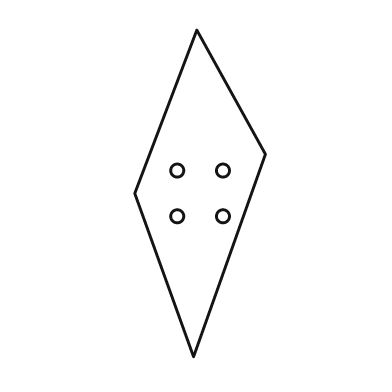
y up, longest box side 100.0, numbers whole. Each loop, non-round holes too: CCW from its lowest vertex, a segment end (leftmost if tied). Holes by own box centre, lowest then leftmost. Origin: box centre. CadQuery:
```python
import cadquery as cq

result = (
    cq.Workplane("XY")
    .moveTo(-2.0, -50.0)
    .lineTo(20.0, 12.0)
    .lineTo(-1.0, 50.0)
    .lineTo(-20.0, 0.0)
    .close()
    .moveTo(-7.0, -7.0)
    .circle(2.0)
    .moveTo(7.0, -7.0)
    .circle(2.0)
    .moveTo(-7.0, 7.0)
    .circle(2.0)
    .moveTo(7.0, 7.0)
    .circle(2.0)
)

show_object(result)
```